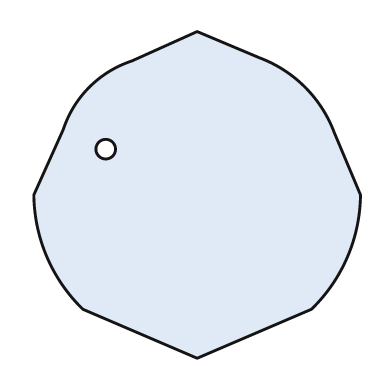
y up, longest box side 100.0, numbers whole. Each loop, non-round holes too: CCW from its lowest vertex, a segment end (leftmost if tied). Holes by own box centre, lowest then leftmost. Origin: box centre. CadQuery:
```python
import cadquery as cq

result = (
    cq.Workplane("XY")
    .moveTo(0.0, -50.0)
    .lineTo(35.0, -35.0)
    .threePointArc((46.0, -19.0), (50.0, 0.0))
    .lineTo(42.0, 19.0)
    .threePointArc((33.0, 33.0), (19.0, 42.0))
    .lineTo(0.0, 50.0)
    .lineTo(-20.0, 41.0)
    .threePointArc((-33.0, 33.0), (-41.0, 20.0))
    .lineTo(-50.0, 0.0)
    .threePointArc((-46.0, -19.0), (-35.0, -35.0))
    .close()
    .moveTo(-28.0, 14.0)
    .circle(3.0)
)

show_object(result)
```